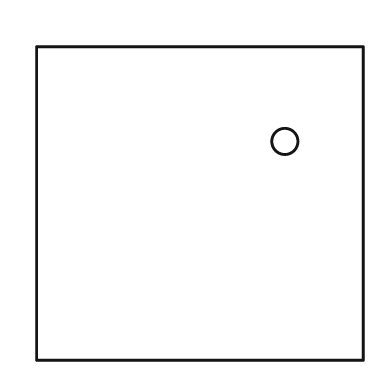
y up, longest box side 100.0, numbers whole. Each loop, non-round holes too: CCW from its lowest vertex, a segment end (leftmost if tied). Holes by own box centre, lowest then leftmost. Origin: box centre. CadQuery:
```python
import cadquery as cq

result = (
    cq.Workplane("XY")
    .moveTo(-50.0, -48.0)
    .lineTo(50.0, -48.0)
    .lineTo(50.0, 48.0)
    .lineTo(-50.0, 48.0)
    .close()
    .moveTo(26.0, 19.0)
    .circle(4.0)
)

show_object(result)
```